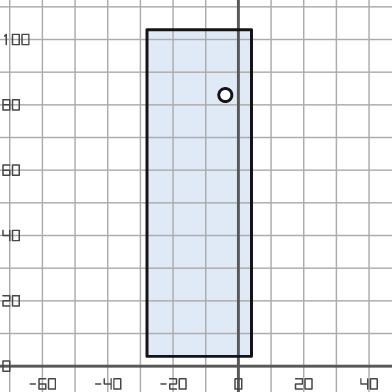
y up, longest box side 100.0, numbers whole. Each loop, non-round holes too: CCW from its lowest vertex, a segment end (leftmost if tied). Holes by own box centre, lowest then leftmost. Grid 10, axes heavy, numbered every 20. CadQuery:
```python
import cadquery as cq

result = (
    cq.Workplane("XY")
    .moveTo(-28.0, 3.0)
    .lineTo(4.0, 3.0)
    .lineTo(4.0, 103.0)
    .lineTo(-28.0, 103.0)
    .close()
    .moveTo(-4.0, 83.0)
    .circle(2.0)
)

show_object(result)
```